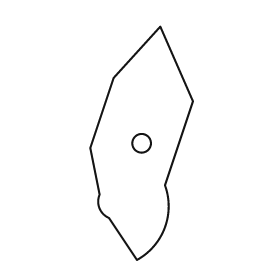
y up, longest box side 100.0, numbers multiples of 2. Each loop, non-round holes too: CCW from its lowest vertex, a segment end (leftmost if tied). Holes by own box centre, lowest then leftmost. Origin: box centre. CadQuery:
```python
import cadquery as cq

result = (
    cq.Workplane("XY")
    .moveTo(-2.0, -50.0)
    .threePointArc((10.0, -36.0), (10.0, -18.0))
    .lineTo(22.0, 18.0)
    .lineTo(8.0, 50.0)
    .lineTo(-12.0, 28.0)
    .lineTo(-22.0, -2.0)
    .lineTo(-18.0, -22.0)
    .threePointArc((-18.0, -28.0), (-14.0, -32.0))
    .close()
    .moveTo(0.0, 0.0)
    .circle(4.0)
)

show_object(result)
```